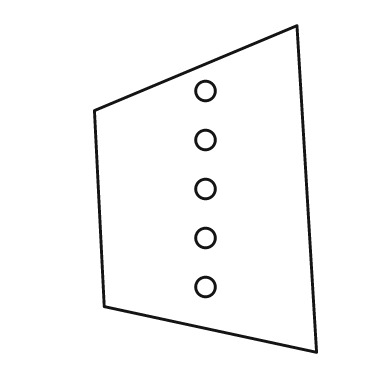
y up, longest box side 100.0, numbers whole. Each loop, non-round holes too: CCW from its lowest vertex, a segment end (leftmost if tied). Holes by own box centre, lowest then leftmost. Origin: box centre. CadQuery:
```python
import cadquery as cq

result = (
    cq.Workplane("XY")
    .moveTo(34.0, -50.0)
    .lineTo(28.0, 50.0)
    .lineTo(-34.0, 24.0)
    .lineTo(-31.0, -36.0)
    .close()
    .moveTo(0.0, -30.0)
    .circle(3.0)
    .moveTo(0.0, -15.0)
    .circle(3.0)
    .moveTo(0.0, 0.0)
    .circle(3.0)
    .moveTo(0.0, 15.0)
    .circle(3.0)
    .moveTo(0.0, 30.0)
    .circle(3.0)
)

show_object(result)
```